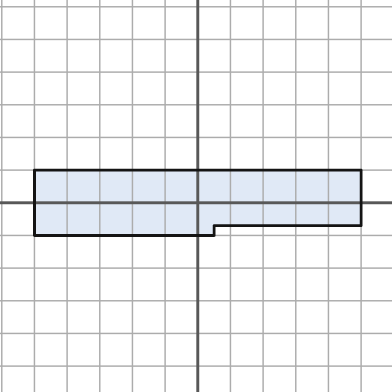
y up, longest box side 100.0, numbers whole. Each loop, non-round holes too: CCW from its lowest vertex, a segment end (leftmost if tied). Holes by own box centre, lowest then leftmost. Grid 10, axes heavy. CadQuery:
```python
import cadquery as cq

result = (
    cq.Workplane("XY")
    .moveTo(-50.0, -10.0)
    .lineTo(5.0, -10.0)
    .lineTo(5.0, -7.0)
    .lineTo(50.0, -7.0)
    .lineTo(50.0, 10.0)
    .lineTo(-50.0, 10.0)
    .close()
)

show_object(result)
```